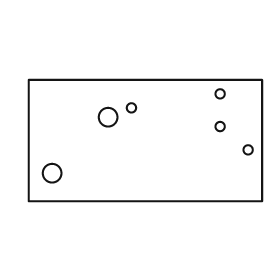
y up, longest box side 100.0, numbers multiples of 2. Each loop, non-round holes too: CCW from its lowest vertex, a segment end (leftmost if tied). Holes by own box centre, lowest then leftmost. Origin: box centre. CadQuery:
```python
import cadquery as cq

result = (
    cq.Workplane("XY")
    .moveTo(-50.0, -26.0)
    .lineTo(50.0, -26.0)
    .lineTo(50.0, 26.0)
    .lineTo(-50.0, 26.0)
    .close()
    .moveTo(-40.0, -14.0)
    .circle(4.0)
    .moveTo(44.0, -4.0)
    .circle(2.0)
    .moveTo(32.0, 6.0)
    .circle(2.0)
    .moveTo(-16.0, 10.0)
    .circle(4.0)
    .moveTo(-6.0, 14.0)
    .circle(2.0)
    .moveTo(32.0, 20.0)
    .circle(2.0)
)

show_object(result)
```